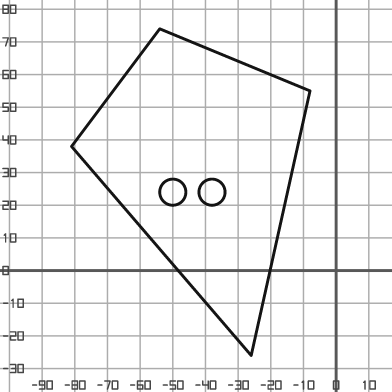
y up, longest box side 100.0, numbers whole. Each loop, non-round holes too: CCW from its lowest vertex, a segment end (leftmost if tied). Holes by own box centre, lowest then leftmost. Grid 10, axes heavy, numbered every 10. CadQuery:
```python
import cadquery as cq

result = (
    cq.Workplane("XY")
    .moveTo(-26.0, -26.0)
    .lineTo(-8.0, 55.0)
    .lineTo(-54.0, 74.0)
    .lineTo(-81.0, 38.0)
    .close()
    .moveTo(-50.0, 24.0)
    .circle(4.0)
    .moveTo(-38.0, 24.0)
    .circle(4.0)
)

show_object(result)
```